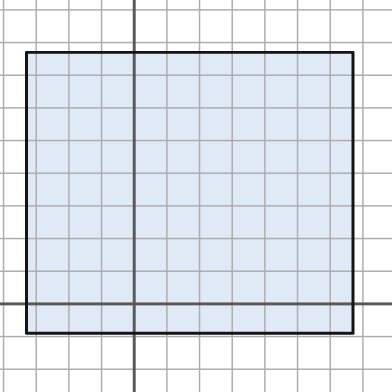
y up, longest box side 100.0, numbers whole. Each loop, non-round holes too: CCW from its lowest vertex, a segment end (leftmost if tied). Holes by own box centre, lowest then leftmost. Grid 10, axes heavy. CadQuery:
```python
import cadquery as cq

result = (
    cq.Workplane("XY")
    .moveTo(-33.0, -9.0)
    .lineTo(67.0, -9.0)
    .lineTo(67.0, 77.0)
    .lineTo(-33.0, 77.0)
    .close()
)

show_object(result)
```